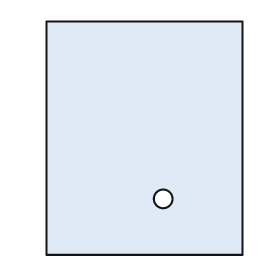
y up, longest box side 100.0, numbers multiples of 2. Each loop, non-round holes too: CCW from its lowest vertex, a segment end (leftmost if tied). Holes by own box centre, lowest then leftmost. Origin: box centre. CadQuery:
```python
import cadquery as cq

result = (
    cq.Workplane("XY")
    .moveTo(-42.0, -50.0)
    .lineTo(42.0, -50.0)
    .lineTo(42.0, 50.0)
    .lineTo(-42.0, 50.0)
    .close()
    .moveTo(8.0, -26.0)
    .circle(4.0)
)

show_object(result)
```